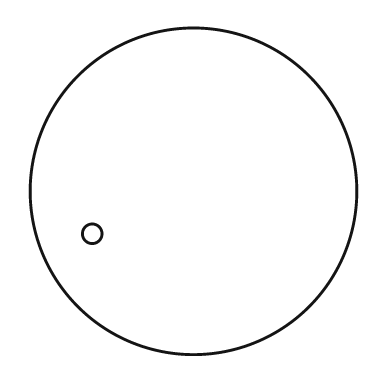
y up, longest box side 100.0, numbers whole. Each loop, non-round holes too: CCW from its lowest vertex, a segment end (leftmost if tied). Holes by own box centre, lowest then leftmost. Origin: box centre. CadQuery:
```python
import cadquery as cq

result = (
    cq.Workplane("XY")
    .moveTo(0.0, 0.0)
    .circle(50.0)
    .moveTo(-31.0, -13.0)
    .circle(3.0)
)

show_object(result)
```